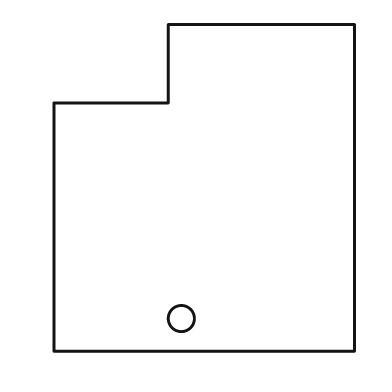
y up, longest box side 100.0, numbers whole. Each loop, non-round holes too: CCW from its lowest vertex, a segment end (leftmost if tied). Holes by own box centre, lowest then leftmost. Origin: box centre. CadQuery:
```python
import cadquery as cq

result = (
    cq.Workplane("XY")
    .moveTo(-46.0, -50.0)
    .lineTo(46.0, -50.0)
    .lineTo(46.0, 50.0)
    .lineTo(-11.0, 50.0)
    .lineTo(-11.0, 26.0)
    .lineTo(-46.0, 26.0)
    .close()
    .moveTo(-7.0, -40.0)
    .circle(4.0)
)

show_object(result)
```